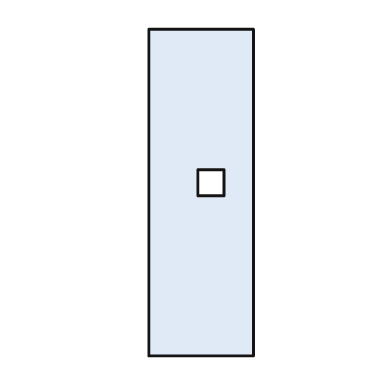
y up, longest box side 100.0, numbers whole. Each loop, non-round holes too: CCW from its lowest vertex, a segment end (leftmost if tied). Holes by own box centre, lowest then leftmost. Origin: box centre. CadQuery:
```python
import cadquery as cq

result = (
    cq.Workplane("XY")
    .moveTo(-16.0, -50.0)
    .lineTo(16.0, -50.0)
    .lineTo(16.0, 50.0)
    .lineTo(-16.0, 50.0)
    .close()
    .moveTo(-1.0, -1.0)
    .lineTo(7.0, -1.0)
    .lineTo(7.0, 7.0)
    .lineTo(-1.0, 7.0)
    .close()
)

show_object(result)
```